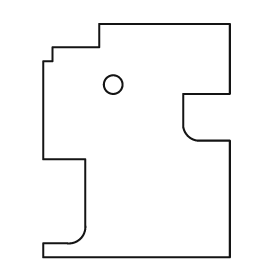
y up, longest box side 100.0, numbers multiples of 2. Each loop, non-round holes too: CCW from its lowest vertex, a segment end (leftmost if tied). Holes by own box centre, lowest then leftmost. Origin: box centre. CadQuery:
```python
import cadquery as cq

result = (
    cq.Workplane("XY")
    .moveTo(-40.0, -50.0)
    .lineTo(40.0, -50.0)
    .lineTo(40.0, 0.0)
    .lineTo(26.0, 0.0)
    .threePointArc((22.0, 2.0), (20.0, 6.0))
    .lineTo(20.0, 20.0)
    .lineTo(40.0, 20.0)
    .lineTo(40.0, 50.0)
    .lineTo(-16.0, 50.0)
    .lineTo(-16.0, 40.0)
    .lineTo(-36.0, 40.0)
    .lineTo(-36.0, 34.0)
    .lineTo(-40.0, 34.0)
    .lineTo(-40.0, -8.0)
    .lineTo(-22.0, -8.0)
    .lineTo(-22.0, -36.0)
    .threePointArc((-24.0, -42.0), (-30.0, -44.0))
    .lineTo(-40.0, -44.0)
    .close()
    .moveTo(-10.0, 24.0)
    .circle(4.0)
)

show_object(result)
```